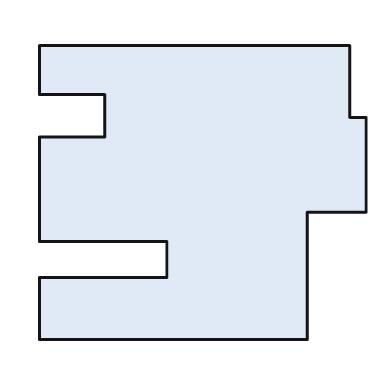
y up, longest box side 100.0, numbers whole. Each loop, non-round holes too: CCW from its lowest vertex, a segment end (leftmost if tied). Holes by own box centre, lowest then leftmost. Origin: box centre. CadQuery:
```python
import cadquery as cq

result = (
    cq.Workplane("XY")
    .moveTo(-50.0, -45.0)
    .lineTo(32.0, -45.0)
    .lineTo(32.0, -6.0)
    .lineTo(50.0, -6.0)
    .lineTo(50.0, 23.0)
    .lineTo(45.0, 23.0)
    .lineTo(45.0, 45.0)
    .lineTo(-50.0, 45.0)
    .lineTo(-50.0, 30.0)
    .lineTo(-30.0, 30.0)
    .lineTo(-30.0, 17.0)
    .lineTo(-50.0, 17.0)
    .lineTo(-50.0, -15.0)
    .lineTo(-11.0, -15.0)
    .lineTo(-11.0, -26.0)
    .lineTo(-50.0, -26.0)
    .close()
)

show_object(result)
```